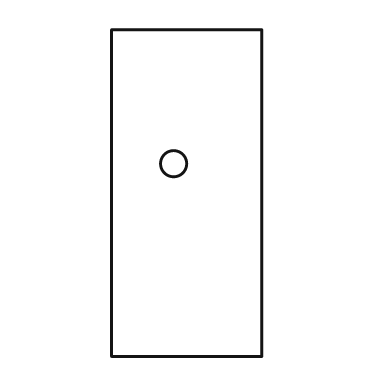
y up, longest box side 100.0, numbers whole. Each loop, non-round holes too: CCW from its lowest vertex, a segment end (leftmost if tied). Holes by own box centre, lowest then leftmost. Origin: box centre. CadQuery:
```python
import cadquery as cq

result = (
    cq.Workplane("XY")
    .moveTo(-23.0, -50.0)
    .lineTo(23.0, -50.0)
    .lineTo(23.0, 50.0)
    .lineTo(-23.0, 50.0)
    .close()
    .moveTo(-4.0, 9.0)
    .circle(4.0)
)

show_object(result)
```